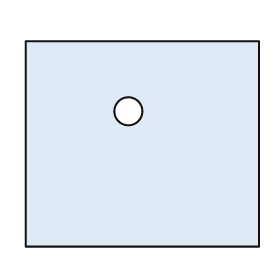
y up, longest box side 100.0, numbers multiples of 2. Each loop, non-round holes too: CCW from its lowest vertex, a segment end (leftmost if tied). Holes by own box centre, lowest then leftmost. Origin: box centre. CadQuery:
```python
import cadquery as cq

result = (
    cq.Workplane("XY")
    .moveTo(-50.0, -44.0)
    .lineTo(50.0, -44.0)
    .lineTo(50.0, 44.0)
    .lineTo(-50.0, 44.0)
    .close()
    .moveTo(-6.0, 14.0)
    .circle(6.0)
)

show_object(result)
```